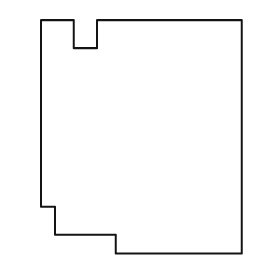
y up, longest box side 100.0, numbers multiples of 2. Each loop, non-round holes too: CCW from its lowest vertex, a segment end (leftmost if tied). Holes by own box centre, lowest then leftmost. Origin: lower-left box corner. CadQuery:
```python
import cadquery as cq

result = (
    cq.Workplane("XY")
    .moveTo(32.0, 0.0)
    .lineTo(86.0, 0.0)
    .lineTo(86.0, 100.0)
    .lineTo(24.0, 100.0)
    .lineTo(24.0, 88.0)
    .lineTo(14.0, 88.0)
    .lineTo(14.0, 100.0)
    .lineTo(0.0, 100.0)
    .lineTo(0.0, 20.0)
    .lineTo(6.0, 20.0)
    .lineTo(6.0, 8.0)
    .lineTo(32.0, 8.0)
    .close()
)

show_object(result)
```